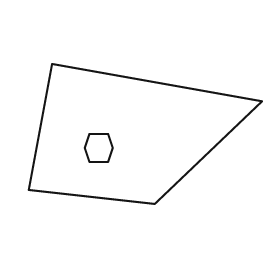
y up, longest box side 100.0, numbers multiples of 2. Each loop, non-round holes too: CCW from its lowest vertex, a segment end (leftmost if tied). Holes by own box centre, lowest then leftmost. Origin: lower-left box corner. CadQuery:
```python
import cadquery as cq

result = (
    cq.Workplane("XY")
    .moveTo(54.0, 0.0)
    .lineTo(100.0, 44.0)
    .lineTo(10.0, 60.0)
    .lineTo(0.0, 6.0)
    .close()
    .moveTo(26.0, 18.0)
    .lineTo(34.0, 18.0)
    .lineTo(36.0, 24.0)
    .lineTo(34.0, 30.0)
    .lineTo(26.0, 30.0)
    .lineTo(24.0, 24.0)
    .close()
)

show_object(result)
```